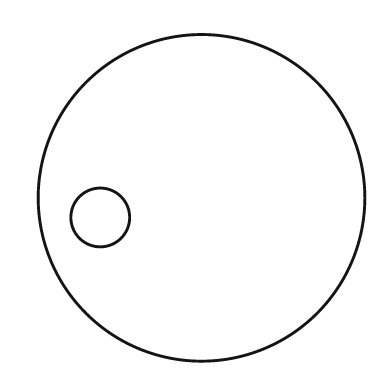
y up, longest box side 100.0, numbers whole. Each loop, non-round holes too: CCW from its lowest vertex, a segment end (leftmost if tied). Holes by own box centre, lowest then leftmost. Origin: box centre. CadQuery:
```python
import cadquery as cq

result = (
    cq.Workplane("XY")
    .moveTo(0.0, 0.0)
    .circle(50.0)
    .moveTo(-31.0, -6.0)
    .circle(9.0)
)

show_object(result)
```